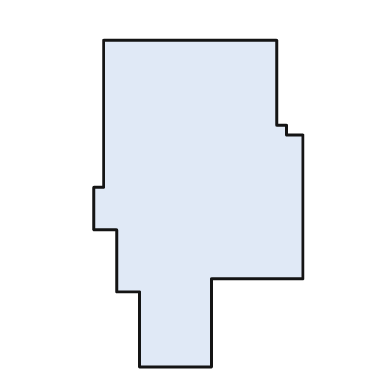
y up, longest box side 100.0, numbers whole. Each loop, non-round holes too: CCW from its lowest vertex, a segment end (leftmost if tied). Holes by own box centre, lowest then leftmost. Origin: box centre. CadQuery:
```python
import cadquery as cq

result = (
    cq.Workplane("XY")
    .moveTo(-18.0, -50.0)
    .lineTo(4.0, -50.0)
    .lineTo(4.0, -23.0)
    .lineTo(32.0, -23.0)
    .lineTo(32.0, 21.0)
    .lineTo(27.0, 21.0)
    .lineTo(27.0, 24.0)
    .lineTo(24.0, 24.0)
    .lineTo(24.0, 50.0)
    .lineTo(-29.0, 50.0)
    .lineTo(-29.0, 5.0)
    .lineTo(-32.0, 5.0)
    .lineTo(-32.0, -8.0)
    .lineTo(-25.0, -8.0)
    .lineTo(-25.0, -27.0)
    .lineTo(-18.0, -27.0)
    .close()
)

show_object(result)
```